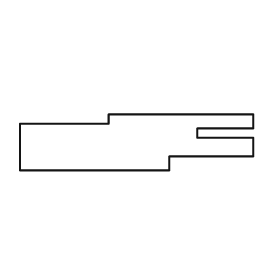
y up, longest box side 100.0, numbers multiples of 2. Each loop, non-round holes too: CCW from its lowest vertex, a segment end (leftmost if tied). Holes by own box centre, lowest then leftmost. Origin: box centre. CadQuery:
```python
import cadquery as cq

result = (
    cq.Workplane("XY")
    .moveTo(-50.0, -12.0)
    .lineTo(14.0, -12.0)
    .lineTo(14.0, -6.0)
    .lineTo(50.0, -6.0)
    .lineTo(50.0, 2.0)
    .lineTo(26.0, 2.0)
    .lineTo(26.0, 6.0)
    .lineTo(50.0, 6.0)
    .lineTo(50.0, 12.0)
    .lineTo(-12.0, 12.0)
    .lineTo(-12.0, 8.0)
    .lineTo(-50.0, 8.0)
    .close()
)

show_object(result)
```